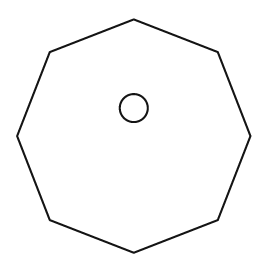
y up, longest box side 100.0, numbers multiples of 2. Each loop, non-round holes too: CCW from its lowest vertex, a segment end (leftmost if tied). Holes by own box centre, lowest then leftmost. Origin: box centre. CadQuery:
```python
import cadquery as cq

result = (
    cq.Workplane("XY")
    .moveTo(0.0, -50.0)
    .lineTo(36.0, -36.0)
    .lineTo(50.0, 0.0)
    .lineTo(36.0, 36.0)
    .lineTo(0.0, 50.0)
    .lineTo(-36.0, 36.0)
    .lineTo(-50.0, 0.0)
    .lineTo(-36.0, -36.0)
    .close()
    .moveTo(0.0, 12.0)
    .circle(6.0)
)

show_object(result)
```